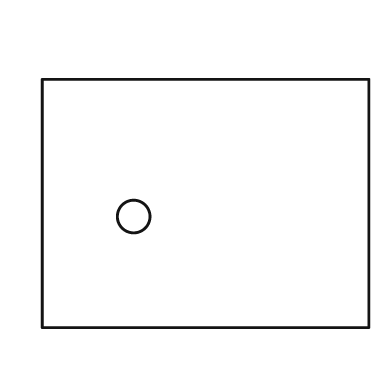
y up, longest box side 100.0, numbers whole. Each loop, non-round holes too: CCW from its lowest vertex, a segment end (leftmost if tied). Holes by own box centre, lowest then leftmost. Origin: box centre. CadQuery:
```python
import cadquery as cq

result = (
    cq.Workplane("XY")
    .moveTo(-50.0, -38.0)
    .lineTo(50.0, -38.0)
    .lineTo(50.0, 38.0)
    .lineTo(-50.0, 38.0)
    .close()
    .moveTo(-22.0, -4.0)
    .circle(5.0)
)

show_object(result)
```